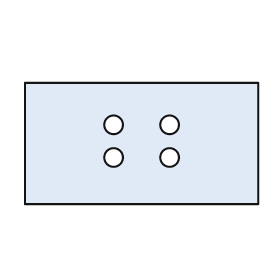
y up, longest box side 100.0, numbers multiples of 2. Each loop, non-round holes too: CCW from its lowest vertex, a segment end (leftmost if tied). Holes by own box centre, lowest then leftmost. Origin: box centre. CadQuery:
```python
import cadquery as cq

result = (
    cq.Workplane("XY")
    .moveTo(-50.0, -26.0)
    .lineTo(50.0, -26.0)
    .lineTo(50.0, 26.0)
    .lineTo(-50.0, 26.0)
    .close()
    .moveTo(-12.0, -6.0)
    .circle(4.0)
    .moveTo(12.0, -6.0)
    .circle(4.0)
    .moveTo(-12.0, 8.0)
    .circle(4.0)
    .moveTo(12.0, 8.0)
    .circle(4.0)
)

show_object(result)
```